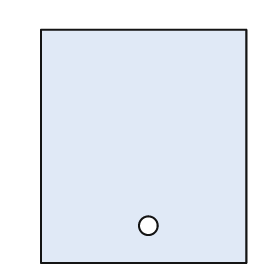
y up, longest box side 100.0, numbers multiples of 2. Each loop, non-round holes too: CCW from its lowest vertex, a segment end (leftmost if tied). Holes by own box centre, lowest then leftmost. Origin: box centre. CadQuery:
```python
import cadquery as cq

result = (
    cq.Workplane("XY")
    .moveTo(-44.0, -50.0)
    .lineTo(44.0, -50.0)
    .lineTo(44.0, 50.0)
    .lineTo(-44.0, 50.0)
    .close()
    .moveTo(2.0, -34.0)
    .circle(4.0)
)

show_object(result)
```